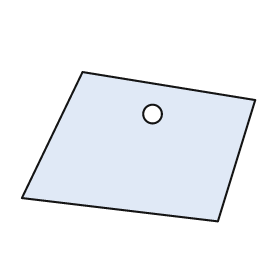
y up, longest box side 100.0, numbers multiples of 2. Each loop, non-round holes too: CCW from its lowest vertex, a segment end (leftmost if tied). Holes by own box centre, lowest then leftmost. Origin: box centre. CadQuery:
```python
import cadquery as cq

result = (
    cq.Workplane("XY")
    .moveTo(34.0, -32.0)
    .lineTo(50.0, 20.0)
    .lineTo(-24.0, 32.0)
    .lineTo(-50.0, -22.0)
    .close()
    .moveTo(6.0, 14.0)
    .circle(4.0)
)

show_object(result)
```